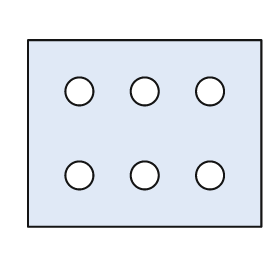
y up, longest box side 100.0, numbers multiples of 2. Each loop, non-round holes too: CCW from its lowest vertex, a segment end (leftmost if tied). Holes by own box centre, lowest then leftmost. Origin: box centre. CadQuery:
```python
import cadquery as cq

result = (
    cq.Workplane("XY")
    .moveTo(-50.0, -40.0)
    .lineTo(50.0, -40.0)
    .lineTo(50.0, 40.0)
    .lineTo(-50.0, 40.0)
    .close()
    .moveTo(-28.0, -18.0)
    .circle(6.0)
    .moveTo(0.0, -18.0)
    .circle(6.0)
    .moveTo(28.0, -18.0)
    .circle(6.0)
    .moveTo(-28.0, 18.0)
    .circle(6.0)
    .moveTo(0.0, 18.0)
    .circle(6.0)
    .moveTo(28.0, 18.0)
    .circle(6.0)
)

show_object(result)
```